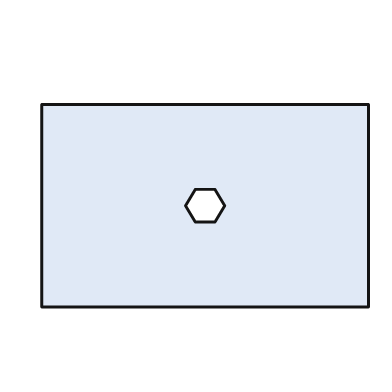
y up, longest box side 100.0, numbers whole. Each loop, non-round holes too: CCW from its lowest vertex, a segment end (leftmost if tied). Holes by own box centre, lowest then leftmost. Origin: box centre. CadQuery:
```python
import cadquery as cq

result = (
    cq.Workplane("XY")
    .moveTo(-50.0, -31.0)
    .lineTo(50.0, -31.0)
    .lineTo(50.0, 31.0)
    .lineTo(-50.0, 31.0)
    .close()
    .moveTo(-3.0, -5.0)
    .lineTo(3.0, -5.0)
    .lineTo(6.0, 0.0)
    .lineTo(3.0, 5.0)
    .lineTo(-3.0, 5.0)
    .lineTo(-6.0, 0.0)
    .close()
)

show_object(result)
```